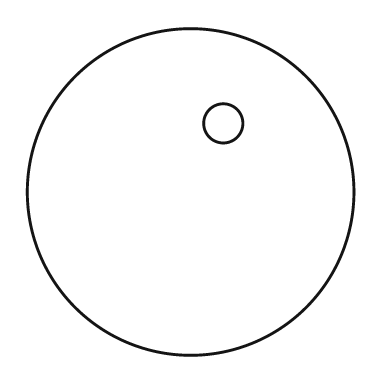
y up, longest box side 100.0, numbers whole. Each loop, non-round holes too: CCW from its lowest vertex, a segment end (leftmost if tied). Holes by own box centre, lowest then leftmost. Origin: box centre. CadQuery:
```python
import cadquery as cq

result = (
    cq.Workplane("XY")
    .moveTo(0.0, 0.0)
    .circle(50.0)
    .moveTo(10.0, 21.0)
    .circle(6.0)
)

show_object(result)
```